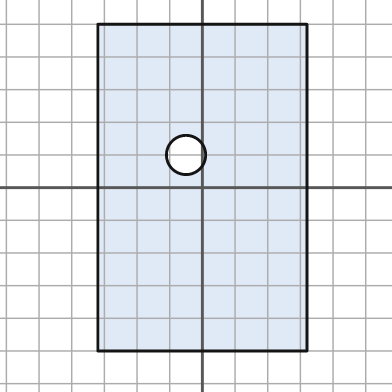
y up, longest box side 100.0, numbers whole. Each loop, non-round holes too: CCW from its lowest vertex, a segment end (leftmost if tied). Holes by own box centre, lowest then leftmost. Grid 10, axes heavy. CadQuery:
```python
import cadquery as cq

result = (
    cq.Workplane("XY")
    .moveTo(-32.0, -50.0)
    .lineTo(32.0, -50.0)
    .lineTo(32.0, 50.0)
    .lineTo(-32.0, 50.0)
    .close()
    .moveTo(-5.0, 10.0)
    .circle(6.0)
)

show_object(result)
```